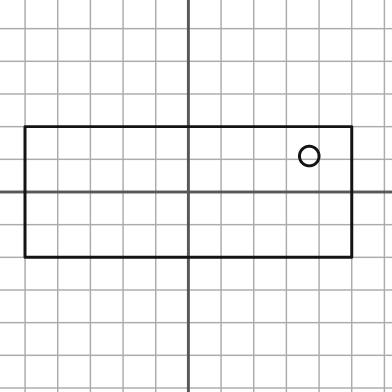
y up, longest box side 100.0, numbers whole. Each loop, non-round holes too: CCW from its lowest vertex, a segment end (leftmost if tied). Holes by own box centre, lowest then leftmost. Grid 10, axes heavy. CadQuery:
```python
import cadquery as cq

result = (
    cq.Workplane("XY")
    .moveTo(-50.0, -20.0)
    .lineTo(50.0, -20.0)
    .lineTo(50.0, 20.0)
    .lineTo(-50.0, 20.0)
    .close()
    .moveTo(37.0, 11.0)
    .circle(3.0)
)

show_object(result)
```